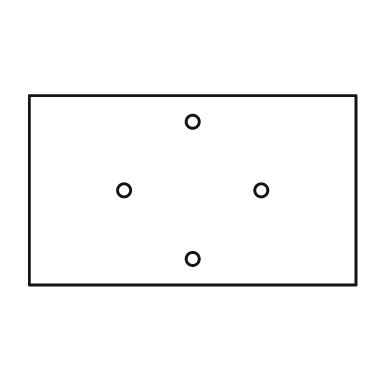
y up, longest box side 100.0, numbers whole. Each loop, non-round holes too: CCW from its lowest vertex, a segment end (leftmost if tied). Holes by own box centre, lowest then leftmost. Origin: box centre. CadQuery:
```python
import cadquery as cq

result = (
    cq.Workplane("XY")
    .moveTo(-50.0, -29.0)
    .lineTo(50.0, -29.0)
    .lineTo(50.0, 29.0)
    .lineTo(-50.0, 29.0)
    .close()
    .moveTo(0.0, -21.0)
    .circle(2.0)
    .moveTo(-21.0, 0.0)
    .circle(2.0)
    .moveTo(21.0, 0.0)
    .circle(2.0)
    .moveTo(0.0, 21.0)
    .circle(2.0)
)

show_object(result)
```